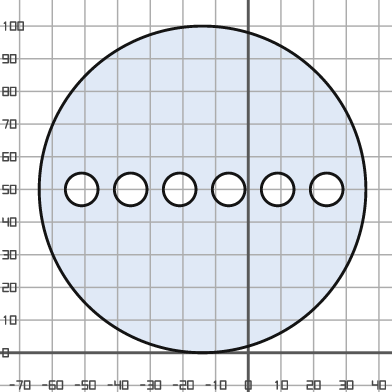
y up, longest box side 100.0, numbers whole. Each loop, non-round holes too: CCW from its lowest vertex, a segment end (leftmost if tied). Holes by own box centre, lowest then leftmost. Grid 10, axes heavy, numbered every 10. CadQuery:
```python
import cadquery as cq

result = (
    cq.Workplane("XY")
    .moveTo(-14.0, 50.0)
    .circle(50.0)
    .moveTo(-51.0, 50.0)
    .circle(5.0)
    .moveTo(-36.0, 50.0)
    .circle(5.0)
    .moveTo(-21.0, 50.0)
    .circle(5.0)
    .moveTo(-6.0, 50.0)
    .circle(5.0)
    .moveTo(9.0, 50.0)
    .circle(5.0)
    .moveTo(24.0, 50.0)
    .circle(5.0)
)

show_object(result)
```